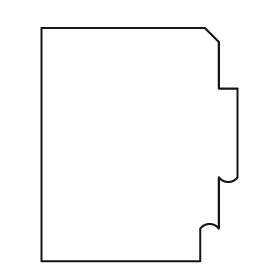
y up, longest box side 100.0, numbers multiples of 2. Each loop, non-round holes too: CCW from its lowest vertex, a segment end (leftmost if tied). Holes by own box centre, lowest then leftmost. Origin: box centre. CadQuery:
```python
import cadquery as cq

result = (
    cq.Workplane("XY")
    .moveTo(-42.0, -50.0)
    .lineTo(26.0, -50.0)
    .lineTo(26.0, -36.0)
    .threePointArc((30.0, -34.0), (34.0, -36.0))
    .lineTo(34.0, -14.0)
    .threePointArc((38.0, -16.0), (42.0, -14.0))
    .lineTo(42.0, 24.0)
    .lineTo(34.0, 24.0)
    .lineTo(34.0, 44.0)
    .lineTo(28.0, 50.0)
    .lineTo(-42.0, 50.0)
    .close()
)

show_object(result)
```